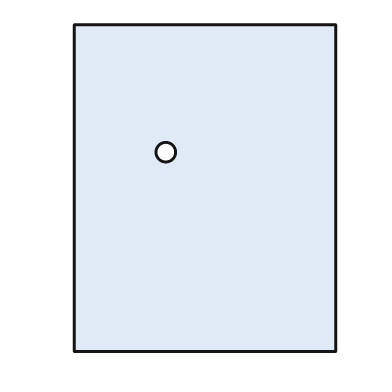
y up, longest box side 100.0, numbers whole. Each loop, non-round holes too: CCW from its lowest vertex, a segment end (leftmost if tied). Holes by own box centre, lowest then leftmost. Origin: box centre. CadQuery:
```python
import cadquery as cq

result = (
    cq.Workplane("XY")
    .moveTo(-40.0, -50.0)
    .lineTo(40.0, -50.0)
    .lineTo(40.0, 50.0)
    .lineTo(-40.0, 50.0)
    .close()
    .moveTo(-12.0, 11.0)
    .circle(3.0)
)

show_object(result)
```